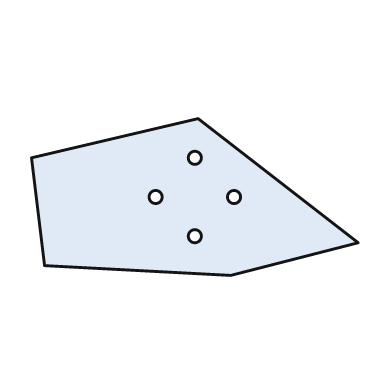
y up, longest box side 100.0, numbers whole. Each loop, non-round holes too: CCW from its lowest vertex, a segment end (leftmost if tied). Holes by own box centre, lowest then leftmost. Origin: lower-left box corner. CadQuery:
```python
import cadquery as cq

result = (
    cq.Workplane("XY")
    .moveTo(61.0, 0.0)
    .lineTo(100.0, 10.0)
    .lineTo(51.0, 48.0)
    .lineTo(0.0, 36.0)
    .lineTo(4.0, 3.0)
    .close()
    .moveTo(50.0, 12.0)
    .circle(2.0)
    .moveTo(38.0, 24.0)
    .circle(2.0)
    .moveTo(62.0, 24.0)
    .circle(2.0)
    .moveTo(50.0, 36.0)
    .circle(2.0)
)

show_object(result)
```